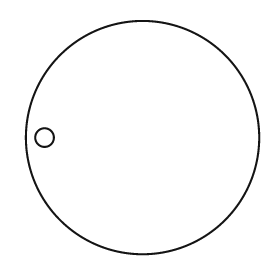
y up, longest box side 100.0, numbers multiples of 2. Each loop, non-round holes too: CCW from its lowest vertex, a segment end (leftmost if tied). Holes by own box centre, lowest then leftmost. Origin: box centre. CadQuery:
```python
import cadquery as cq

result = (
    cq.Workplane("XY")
    .moveTo(0.0, 0.0)
    .circle(50.0)
    .moveTo(-42.0, 0.0)
    .circle(4.0)
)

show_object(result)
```